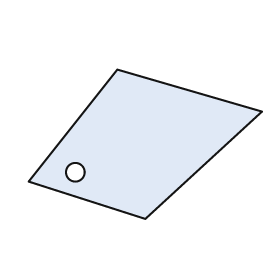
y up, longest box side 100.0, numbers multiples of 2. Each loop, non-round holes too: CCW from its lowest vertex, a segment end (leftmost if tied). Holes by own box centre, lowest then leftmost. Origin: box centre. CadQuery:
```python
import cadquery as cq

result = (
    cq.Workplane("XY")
    .moveTo(0.0, -32.0)
    .lineTo(50.0, 14.0)
    .lineTo(-12.0, 32.0)
    .lineTo(-50.0, -16.0)
    .close()
    .moveTo(-30.0, -12.0)
    .circle(4.0)
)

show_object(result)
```